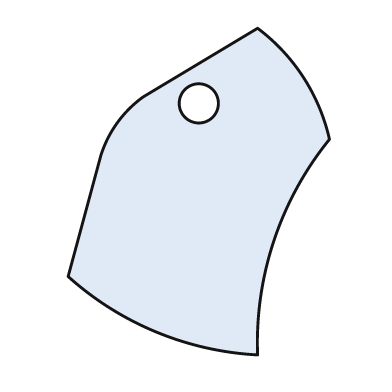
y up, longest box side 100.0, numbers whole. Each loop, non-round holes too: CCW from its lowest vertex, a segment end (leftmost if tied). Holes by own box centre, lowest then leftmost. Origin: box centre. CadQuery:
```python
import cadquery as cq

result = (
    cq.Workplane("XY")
    .moveTo(18.0, -50.0)
    .threePointArc((23.0, -15.0), (40.0, 16.0))
    .threePointArc((32.0, 35.0), (18.0, 50.0))
    .lineTo(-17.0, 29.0)
    .threePointArc((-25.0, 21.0), (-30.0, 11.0))
    .lineTo(-40.0, -26.0)
    .threePointArc((-13.0, -43.0), (18.0, -50.0))
    .close()
    .moveTo(0.0, 27.0)
    .circle(6.0)
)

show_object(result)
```